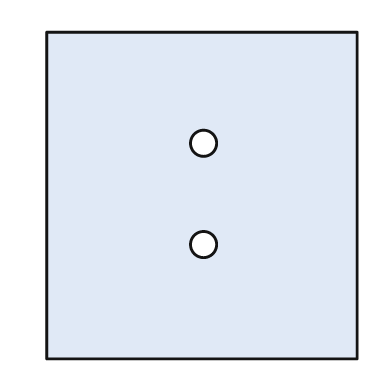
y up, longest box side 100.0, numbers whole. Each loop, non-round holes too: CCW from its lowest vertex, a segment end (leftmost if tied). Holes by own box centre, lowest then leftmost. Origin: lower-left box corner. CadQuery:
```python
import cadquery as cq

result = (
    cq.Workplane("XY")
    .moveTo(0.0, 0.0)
    .lineTo(95.0, 0.0)
    .lineTo(95.0, 100.0)
    .lineTo(0.0, 100.0)
    .close()
    .moveTo(48.0, 35.0)
    .circle(4.0)
    .moveTo(48.0, 66.0)
    .circle(4.0)
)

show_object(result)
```